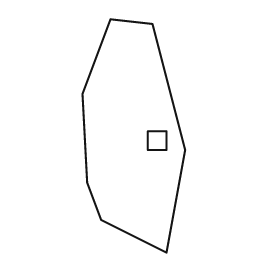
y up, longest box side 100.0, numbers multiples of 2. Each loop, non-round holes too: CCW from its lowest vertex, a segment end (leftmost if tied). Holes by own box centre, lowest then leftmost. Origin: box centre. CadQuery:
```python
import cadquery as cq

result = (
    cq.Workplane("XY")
    .moveTo(14.0, -50.0)
    .lineTo(22.0, -6.0)
    .lineTo(8.0, 48.0)
    .lineTo(-10.0, 50.0)
    .lineTo(-22.0, 18.0)
    .lineTo(-20.0, -20.0)
    .lineTo(-14.0, -36.0)
    .close()
    .moveTo(6.0, -6.0)
    .lineTo(14.0, -6.0)
    .lineTo(14.0, 2.0)
    .lineTo(6.0, 2.0)
    .close()
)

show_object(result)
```